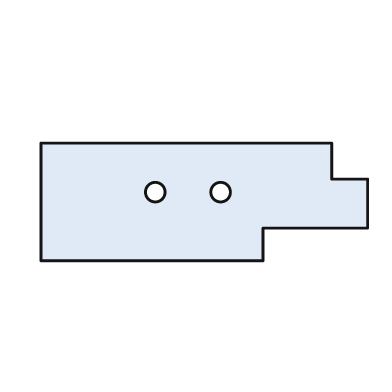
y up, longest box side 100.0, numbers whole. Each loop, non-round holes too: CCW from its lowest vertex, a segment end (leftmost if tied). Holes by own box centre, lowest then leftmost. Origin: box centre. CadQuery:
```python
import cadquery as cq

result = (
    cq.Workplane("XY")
    .moveTo(-50.0, -18.0)
    .lineTo(18.0, -18.0)
    .lineTo(18.0, -8.0)
    .lineTo(50.0, -8.0)
    .lineTo(50.0, 7.0)
    .lineTo(39.0, 7.0)
    .lineTo(39.0, 18.0)
    .lineTo(-50.0, 18.0)
    .close()
    .moveTo(-15.0, 3.0)
    .circle(3.0)
    .moveTo(5.0, 3.0)
    .circle(3.0)
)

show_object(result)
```